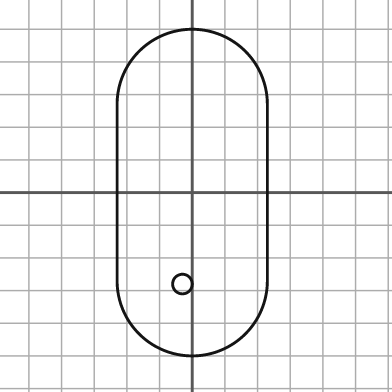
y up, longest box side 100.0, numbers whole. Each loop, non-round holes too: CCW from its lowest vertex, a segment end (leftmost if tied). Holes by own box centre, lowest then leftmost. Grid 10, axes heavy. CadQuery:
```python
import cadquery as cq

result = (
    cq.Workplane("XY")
    .moveTo(-23.0, -27.0)
    .threePointArc((0.0, -50.0), (23.0, -27.0))
    .lineTo(23.0, 27.0)
    .threePointArc((0.0, 50.0), (-23.0, 27.0))
    .close()
    .moveTo(-3.0, -28.0)
    .circle(3.0)
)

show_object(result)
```